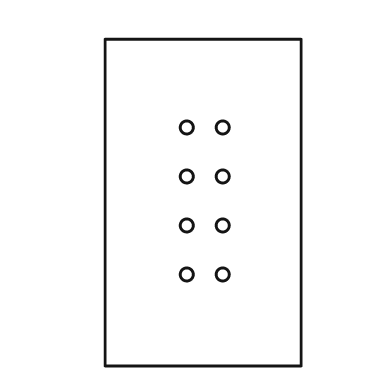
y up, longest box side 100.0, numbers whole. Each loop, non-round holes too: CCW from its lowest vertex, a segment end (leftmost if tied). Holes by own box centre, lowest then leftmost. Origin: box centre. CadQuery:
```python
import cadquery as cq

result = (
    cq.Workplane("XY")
    .moveTo(-30.0, -50.0)
    .lineTo(30.0, -50.0)
    .lineTo(30.0, 50.0)
    .lineTo(-30.0, 50.0)
    .close()
    .moveTo(-5.0, -22.0)
    .circle(2.0)
    .moveTo(6.0, -22.0)
    .circle(2.0)
    .moveTo(-5.0, -7.0)
    .circle(2.0)
    .moveTo(6.0, -7.0)
    .circle(2.0)
    .moveTo(-5.0, 8.0)
    .circle(2.0)
    .moveTo(6.0, 8.0)
    .circle(2.0)
    .moveTo(-5.0, 23.0)
    .circle(2.0)
    .moveTo(6.0, 23.0)
    .circle(2.0)
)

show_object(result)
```